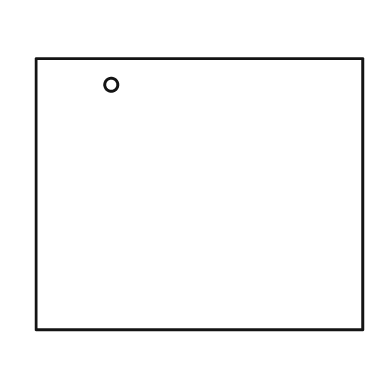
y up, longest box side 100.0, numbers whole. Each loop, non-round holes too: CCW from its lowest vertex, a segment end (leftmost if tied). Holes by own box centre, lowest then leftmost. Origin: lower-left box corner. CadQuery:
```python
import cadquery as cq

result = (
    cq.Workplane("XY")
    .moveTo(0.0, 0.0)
    .lineTo(100.0, 0.0)
    .lineTo(100.0, 83.0)
    .lineTo(0.0, 83.0)
    .close()
    .moveTo(23.0, 75.0)
    .circle(2.0)
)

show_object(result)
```